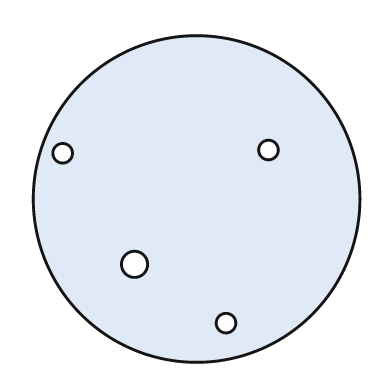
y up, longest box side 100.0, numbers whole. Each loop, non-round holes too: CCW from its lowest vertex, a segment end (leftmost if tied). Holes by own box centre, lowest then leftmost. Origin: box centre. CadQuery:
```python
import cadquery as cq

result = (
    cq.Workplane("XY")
    .moveTo(0.0, 0.0)
    .circle(50.0)
    .moveTo(9.0, -38.0)
    .circle(3.0)
    .moveTo(-19.0, -20.0)
    .circle(4.0)
    .moveTo(-41.0, 14.0)
    .circle(3.0)
    .moveTo(22.0, 15.0)
    .circle(3.0)
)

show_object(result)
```